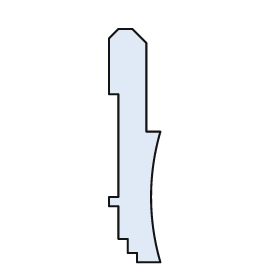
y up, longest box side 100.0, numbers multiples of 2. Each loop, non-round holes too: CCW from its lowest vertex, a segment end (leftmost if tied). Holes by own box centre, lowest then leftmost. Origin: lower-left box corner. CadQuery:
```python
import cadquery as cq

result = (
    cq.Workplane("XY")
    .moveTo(12.0, 0.0)
    .lineTo(22.0, 0.0)
    .threePointArc((18.0, 28.0), (22.0, 56.0))
    .lineTo(16.0, 56.0)
    .lineTo(16.0, 94.0)
    .lineTo(10.0, 100.0)
    .lineTo(4.0, 100.0)
    .lineTo(0.0, 96.0)
    .lineTo(0.0, 72.0)
    .lineTo(4.0, 72.0)
    .lineTo(4.0, 28.0)
    .lineTo(0.0, 28.0)
    .lineTo(0.0, 24.0)
    .lineTo(4.0, 24.0)
    .lineTo(4.0, 10.0)
    .lineTo(8.0, 10.0)
    .lineTo(8.0, 4.0)
    .lineTo(12.0, 4.0)
    .close()
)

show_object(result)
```